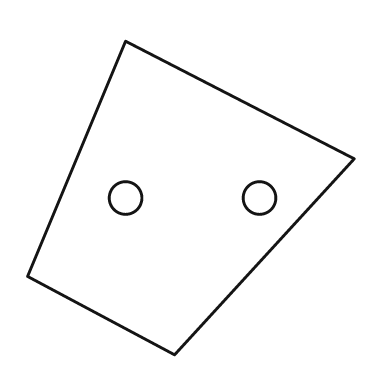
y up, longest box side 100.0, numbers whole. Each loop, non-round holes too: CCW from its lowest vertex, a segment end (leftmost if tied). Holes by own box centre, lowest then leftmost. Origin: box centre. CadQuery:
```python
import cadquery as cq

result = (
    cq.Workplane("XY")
    .moveTo(-5.0, -48.0)
    .lineTo(50.0, 12.0)
    .lineTo(-20.0, 48.0)
    .lineTo(-50.0, -24.0)
    .close()
    .moveTo(-20.0, 0.0)
    .circle(5.0)
    .moveTo(21.0, 0.0)
    .circle(5.0)
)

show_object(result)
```